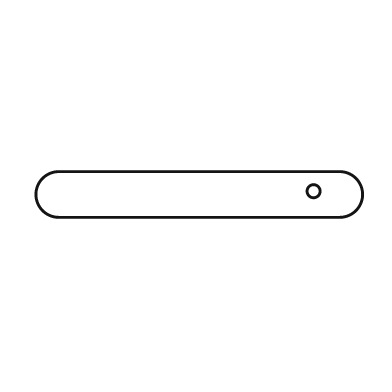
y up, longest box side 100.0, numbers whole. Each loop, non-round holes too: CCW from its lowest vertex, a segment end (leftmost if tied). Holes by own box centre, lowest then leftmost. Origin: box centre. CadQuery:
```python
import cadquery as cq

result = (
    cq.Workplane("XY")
    .moveTo(-43.0, -7.0)
    .lineTo(43.0, -7.0)
    .threePointArc((50.0, 0.0), (43.0, 7.0))
    .lineTo(-43.0, 7.0)
    .threePointArc((-50.0, 0.0), (-43.0, -7.0))
    .close()
    .moveTo(35.0, 1.0)
    .circle(2.0)
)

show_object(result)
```